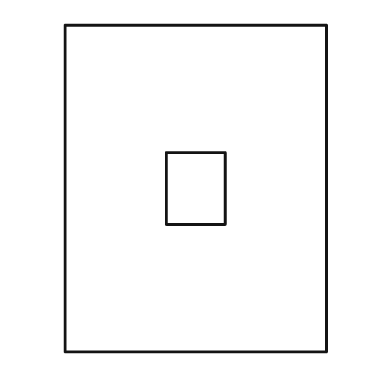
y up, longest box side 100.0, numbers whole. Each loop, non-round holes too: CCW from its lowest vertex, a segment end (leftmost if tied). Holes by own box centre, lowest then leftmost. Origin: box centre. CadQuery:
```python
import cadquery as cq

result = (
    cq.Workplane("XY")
    .moveTo(-40.0, -50.0)
    .lineTo(40.0, -50.0)
    .lineTo(40.0, 50.0)
    .lineTo(-40.0, 50.0)
    .close()
    .moveTo(-9.0, -11.0)
    .lineTo(9.0, -11.0)
    .lineTo(9.0, 11.0)
    .lineTo(-9.0, 11.0)
    .close()
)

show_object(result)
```